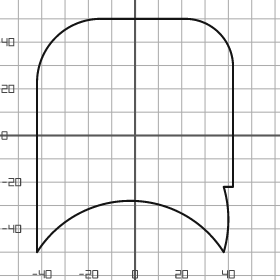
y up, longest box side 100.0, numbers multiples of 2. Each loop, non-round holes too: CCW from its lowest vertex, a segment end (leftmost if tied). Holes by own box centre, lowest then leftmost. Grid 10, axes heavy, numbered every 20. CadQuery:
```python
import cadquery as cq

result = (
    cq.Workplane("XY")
    .moveTo(-42.0, -50.0)
    .threePointArc((-2.0, -28.0), (38.0, -50.0))
    .threePointArc((40.0, -36.0), (38.0, -22.0))
    .lineTo(42.0, -22.0)
    .lineTo(42.0, 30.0)
    .threePointArc((36.0, 44.0), (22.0, 50.0))
    .lineTo(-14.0, 50.0)
    .threePointArc((-34.0, 42.0), (-42.0, 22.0))
    .close()
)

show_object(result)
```